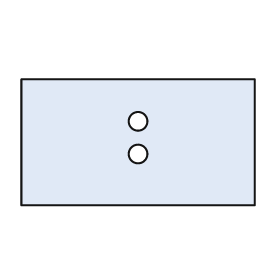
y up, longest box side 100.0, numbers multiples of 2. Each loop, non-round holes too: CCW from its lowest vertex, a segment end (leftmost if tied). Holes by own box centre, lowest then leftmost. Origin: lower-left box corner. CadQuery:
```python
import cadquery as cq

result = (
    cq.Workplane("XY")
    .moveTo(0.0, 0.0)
    .lineTo(100.0, 0.0)
    .lineTo(100.0, 54.0)
    .lineTo(0.0, 54.0)
    .close()
    .moveTo(50.0, 22.0)
    .circle(4.0)
    .moveTo(50.0, 36.0)
    .circle(4.0)
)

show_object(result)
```